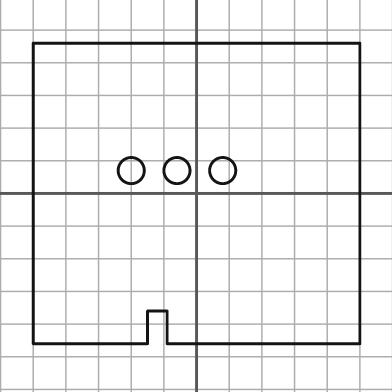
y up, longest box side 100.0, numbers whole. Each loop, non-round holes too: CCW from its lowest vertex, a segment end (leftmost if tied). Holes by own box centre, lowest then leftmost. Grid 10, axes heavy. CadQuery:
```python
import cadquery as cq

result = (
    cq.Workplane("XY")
    .moveTo(-50.0, -46.0)
    .lineTo(-15.0, -46.0)
    .lineTo(-15.0, -36.0)
    .lineTo(-9.0, -36.0)
    .lineTo(-9.0, -46.0)
    .lineTo(50.0, -46.0)
    .lineTo(50.0, 46.0)
    .lineTo(-50.0, 46.0)
    .close()
    .moveTo(-20.0, 7.0)
    .circle(4.0)
    .moveTo(-6.0, 7.0)
    .circle(4.0)
    .moveTo(8.0, 7.0)
    .circle(4.0)
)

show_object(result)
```